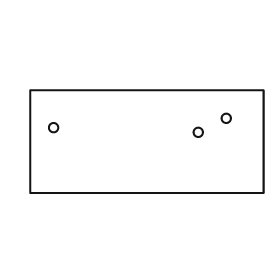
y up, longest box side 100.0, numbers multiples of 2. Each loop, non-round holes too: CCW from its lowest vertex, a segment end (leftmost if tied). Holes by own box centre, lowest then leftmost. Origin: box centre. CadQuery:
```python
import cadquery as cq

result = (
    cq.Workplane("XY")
    .moveTo(-50.0, -22.0)
    .lineTo(50.0, -22.0)
    .lineTo(50.0, 22.0)
    .lineTo(-50.0, 22.0)
    .close()
    .moveTo(22.0, 4.0)
    .circle(2.0)
    .moveTo(-40.0, 6.0)
    .circle(2.0)
    .moveTo(34.0, 10.0)
    .circle(2.0)
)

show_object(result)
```